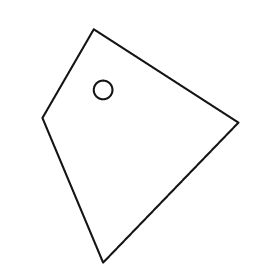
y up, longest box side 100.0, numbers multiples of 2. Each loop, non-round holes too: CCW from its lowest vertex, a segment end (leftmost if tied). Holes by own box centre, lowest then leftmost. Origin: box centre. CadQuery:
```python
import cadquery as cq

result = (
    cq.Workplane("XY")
    .moveTo(-16.0, -50.0)
    .lineTo(42.0, 10.0)
    .lineTo(-20.0, 50.0)
    .lineTo(-42.0, 12.0)
    .close()
    .moveTo(-16.0, 24.0)
    .circle(4.0)
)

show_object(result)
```